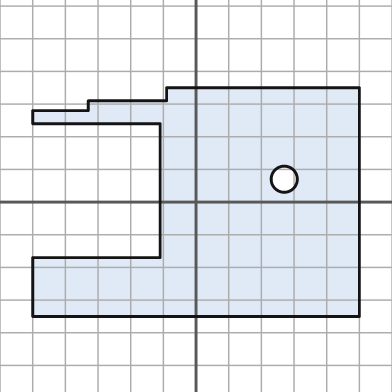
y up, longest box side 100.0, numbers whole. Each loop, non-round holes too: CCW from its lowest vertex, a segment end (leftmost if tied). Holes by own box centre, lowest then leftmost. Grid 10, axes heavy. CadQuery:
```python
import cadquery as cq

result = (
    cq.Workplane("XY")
    .moveTo(-50.0, -35.0)
    .lineTo(50.0, -35.0)
    .lineTo(50.0, 35.0)
    .lineTo(-9.0, 35.0)
    .lineTo(-9.0, 31.0)
    .lineTo(-33.0, 31.0)
    .lineTo(-33.0, 28.0)
    .lineTo(-50.0, 28.0)
    .lineTo(-50.0, 24.0)
    .lineTo(-11.0, 24.0)
    .lineTo(-11.0, -17.0)
    .lineTo(-50.0, -17.0)
    .close()
    .moveTo(27.0, 7.0)
    .circle(4.0)
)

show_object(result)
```